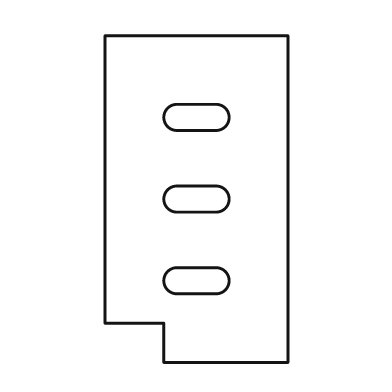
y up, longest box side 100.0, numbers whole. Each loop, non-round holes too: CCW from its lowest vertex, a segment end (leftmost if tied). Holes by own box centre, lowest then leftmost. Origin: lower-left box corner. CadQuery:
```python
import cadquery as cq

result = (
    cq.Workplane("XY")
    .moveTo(18.0, 0.0)
    .lineTo(56.0, 0.0)
    .lineTo(56.0, 100.0)
    .lineTo(0.0, 100.0)
    .lineTo(0.0, 12.0)
    .lineTo(18.0, 12.0)
    .close()
    .moveTo(22.0, 21.0)
    .lineTo(34.0, 21.0)
    .threePointArc((38.0, 25.0), (34.0, 29.0))
    .lineTo(22.0, 29.0)
    .threePointArc((18.0, 25.0), (22.0, 21.0))
    .close()
    .moveTo(22.0, 46.0)
    .lineTo(34.0, 46.0)
    .threePointArc((38.0, 50.0), (34.0, 54.0))
    .lineTo(22.0, 54.0)
    .threePointArc((18.0, 50.0), (22.0, 46.0))
    .close()
    .moveTo(22.0, 71.0)
    .lineTo(34.0, 71.0)
    .threePointArc((38.0, 75.0), (34.0, 79.0))
    .lineTo(22.0, 79.0)
    .threePointArc((18.0, 75.0), (22.0, 71.0))
    .close()
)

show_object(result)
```